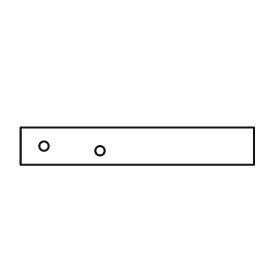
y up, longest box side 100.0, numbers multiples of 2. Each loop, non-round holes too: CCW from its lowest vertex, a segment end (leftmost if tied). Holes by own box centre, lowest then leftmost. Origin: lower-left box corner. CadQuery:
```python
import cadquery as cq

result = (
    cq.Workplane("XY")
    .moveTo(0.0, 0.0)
    .lineTo(100.0, 0.0)
    .lineTo(100.0, 16.0)
    .lineTo(0.0, 16.0)
    .close()
    .moveTo(34.0, 6.0)
    .circle(2.0)
    .moveTo(10.0, 8.0)
    .circle(2.0)
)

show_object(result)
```